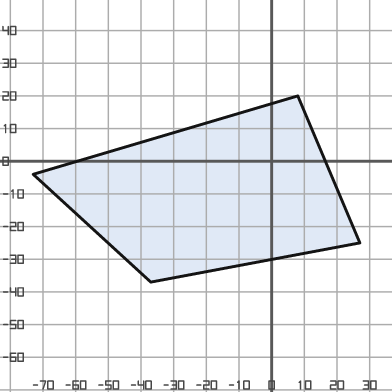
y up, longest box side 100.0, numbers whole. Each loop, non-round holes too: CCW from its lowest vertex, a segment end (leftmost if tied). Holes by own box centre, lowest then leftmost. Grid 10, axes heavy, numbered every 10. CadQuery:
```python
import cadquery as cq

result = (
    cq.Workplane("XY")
    .moveTo(-37.0, -37.0)
    .lineTo(27.0, -25.0)
    .lineTo(8.0, 20.0)
    .lineTo(-73.0, -4.0)
    .close()
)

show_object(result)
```